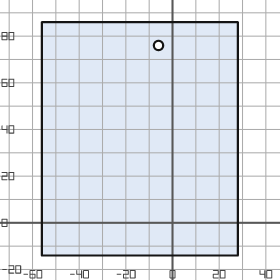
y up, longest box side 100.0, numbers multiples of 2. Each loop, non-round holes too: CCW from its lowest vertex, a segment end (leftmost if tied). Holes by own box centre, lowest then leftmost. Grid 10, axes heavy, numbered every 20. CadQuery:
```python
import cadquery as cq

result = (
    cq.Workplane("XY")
    .moveTo(-56.0, -14.0)
    .lineTo(28.0, -14.0)
    .lineTo(28.0, 86.0)
    .lineTo(-56.0, 86.0)
    .close()
    .moveTo(-6.0, 76.0)
    .circle(2.0)
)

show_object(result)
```